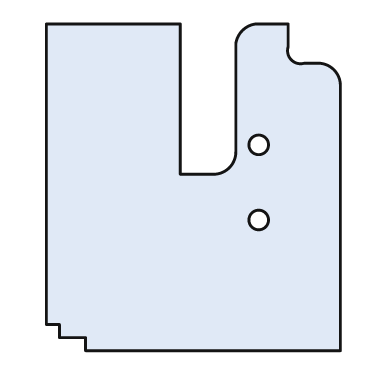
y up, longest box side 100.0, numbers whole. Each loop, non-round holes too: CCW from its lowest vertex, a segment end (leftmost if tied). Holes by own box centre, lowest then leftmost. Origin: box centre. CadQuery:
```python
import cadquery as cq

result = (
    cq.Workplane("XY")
    .moveTo(-33.0, -50.0)
    .lineTo(45.0, -50.0)
    .lineTo(45.0, 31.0)
    .threePointArc((43.0, 36.0), (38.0, 38.0))
    .lineTo(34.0, 38.0)
    .threePointArc((30.0, 39.0), (29.0, 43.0))
    .lineTo(29.0, 50.0)
    .lineTo(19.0, 50.0)
    .threePointArc((15.0, 48.0), (13.0, 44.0))
    .lineTo(13.0, 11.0)
    .threePointArc((11.0, 6.0), (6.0, 4.0))
    .lineTo(-4.0, 4.0)
    .lineTo(-4.0, 50.0)
    .lineTo(-45.0, 50.0)
    .lineTo(-45.0, -42.0)
    .lineTo(-41.0, -42.0)
    .lineTo(-41.0, -46.0)
    .lineTo(-33.0, -46.0)
    .close()
    .moveTo(20.0, -10.0)
    .circle(3.0)
    .moveTo(20.0, 13.0)
    .circle(3.0)
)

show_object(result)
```